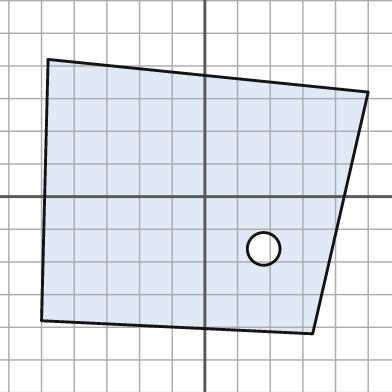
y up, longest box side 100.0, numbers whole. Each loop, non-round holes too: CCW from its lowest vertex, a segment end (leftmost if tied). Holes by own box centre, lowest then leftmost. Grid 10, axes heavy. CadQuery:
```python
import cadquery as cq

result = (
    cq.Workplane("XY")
    .moveTo(33.0, -42.0)
    .lineTo(50.0, 32.0)
    .lineTo(-48.0, 42.0)
    .lineTo(-50.0, -38.0)
    .close()
    .moveTo(18.0, -16.0)
    .circle(5.0)
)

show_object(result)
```